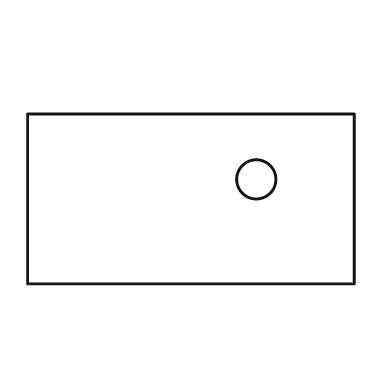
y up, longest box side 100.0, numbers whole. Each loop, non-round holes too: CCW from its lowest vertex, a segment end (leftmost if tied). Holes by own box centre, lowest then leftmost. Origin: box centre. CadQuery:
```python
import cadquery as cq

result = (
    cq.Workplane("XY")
    .moveTo(-50.0, -26.0)
    .lineTo(50.0, -26.0)
    .lineTo(50.0, 26.0)
    .lineTo(-50.0, 26.0)
    .close()
    .moveTo(20.0, 6.0)
    .circle(6.0)
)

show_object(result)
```